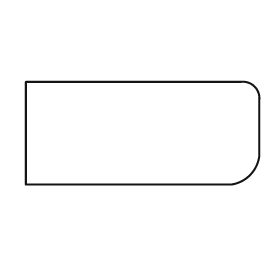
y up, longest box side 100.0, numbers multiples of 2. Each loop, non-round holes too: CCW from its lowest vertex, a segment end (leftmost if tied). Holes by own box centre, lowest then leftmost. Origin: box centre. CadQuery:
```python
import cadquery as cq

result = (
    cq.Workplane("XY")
    .moveTo(-50.0, -22.0)
    .lineTo(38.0, -22.0)
    .threePointArc((46.0, -18.0), (50.0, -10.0))
    .lineTo(50.0, 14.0)
    .threePointArc((48.0, 20.0), (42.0, 22.0))
    .lineTo(-50.0, 22.0)
    .close()
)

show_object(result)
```